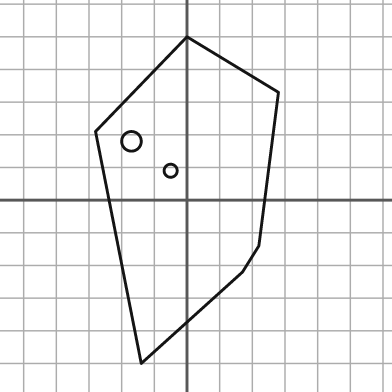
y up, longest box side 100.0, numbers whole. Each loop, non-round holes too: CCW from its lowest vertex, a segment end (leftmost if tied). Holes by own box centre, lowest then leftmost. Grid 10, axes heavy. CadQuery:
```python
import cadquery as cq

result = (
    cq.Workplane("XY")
    .moveTo(-14.0, -50.0)
    .lineTo(17.0, -22.0)
    .lineTo(22.0, -14.0)
    .lineTo(28.0, 33.0)
    .lineTo(0.0, 50.0)
    .lineTo(-28.0, 21.0)
    .close()
    .moveTo(-5.0, 9.0)
    .circle(2.0)
    .moveTo(-17.0, 18.0)
    .circle(3.0)
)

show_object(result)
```